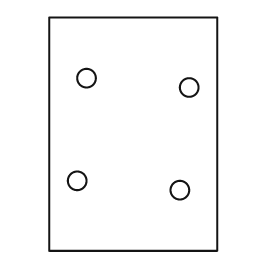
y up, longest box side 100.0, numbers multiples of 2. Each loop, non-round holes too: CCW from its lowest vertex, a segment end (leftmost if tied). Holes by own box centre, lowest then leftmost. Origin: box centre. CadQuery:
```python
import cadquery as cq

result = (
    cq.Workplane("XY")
    .moveTo(-36.0, -50.0)
    .lineTo(36.0, -50.0)
    .lineTo(36.0, 50.0)
    .lineTo(-36.0, 50.0)
    .close()
    .moveTo(20.0, -24.0)
    .circle(4.0)
    .moveTo(-24.0, -20.0)
    .circle(4.0)
    .moveTo(24.0, 20.0)
    .circle(4.0)
    .moveTo(-20.0, 24.0)
    .circle(4.0)
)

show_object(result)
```